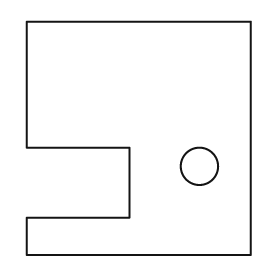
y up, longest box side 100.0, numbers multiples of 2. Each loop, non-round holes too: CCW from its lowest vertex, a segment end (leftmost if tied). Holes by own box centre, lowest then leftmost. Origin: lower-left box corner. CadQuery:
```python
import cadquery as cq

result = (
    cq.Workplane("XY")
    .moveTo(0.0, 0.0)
    .lineTo(96.0, 0.0)
    .lineTo(96.0, 100.0)
    .lineTo(0.0, 100.0)
    .lineTo(0.0, 46.0)
    .lineTo(44.0, 46.0)
    .lineTo(44.0, 16.0)
    .lineTo(0.0, 16.0)
    .close()
    .moveTo(74.0, 38.0)
    .circle(8.0)
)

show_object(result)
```